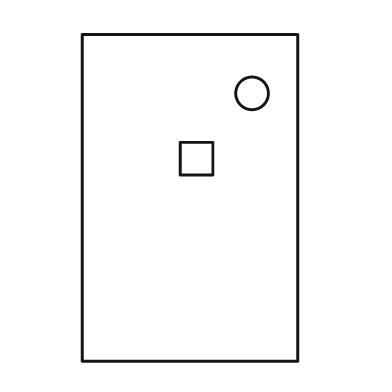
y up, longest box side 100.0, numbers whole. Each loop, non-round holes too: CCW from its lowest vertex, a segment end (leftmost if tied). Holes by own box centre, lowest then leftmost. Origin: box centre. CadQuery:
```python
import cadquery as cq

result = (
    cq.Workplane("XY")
    .moveTo(-33.0, -50.0)
    .lineTo(33.0, -50.0)
    .lineTo(33.0, 50.0)
    .lineTo(-33.0, 50.0)
    .close()
    .moveTo(-3.0, 7.0)
    .lineTo(7.0, 7.0)
    .lineTo(7.0, 17.0)
    .lineTo(-3.0, 17.0)
    .close()
    .moveTo(19.0, 32.0)
    .circle(5.0)
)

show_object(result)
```